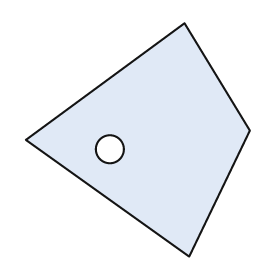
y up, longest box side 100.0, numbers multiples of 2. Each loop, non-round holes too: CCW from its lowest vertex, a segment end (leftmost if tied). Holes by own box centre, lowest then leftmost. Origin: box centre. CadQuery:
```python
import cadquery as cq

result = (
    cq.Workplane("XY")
    .moveTo(22.0, -50.0)
    .lineTo(48.0, 4.0)
    .lineTo(20.0, 50.0)
    .lineTo(-48.0, 0.0)
    .close()
    .moveTo(-12.0, -4.0)
    .circle(6.0)
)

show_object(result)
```